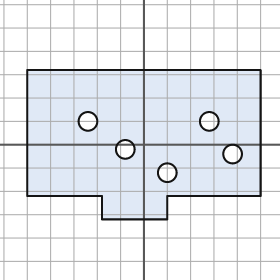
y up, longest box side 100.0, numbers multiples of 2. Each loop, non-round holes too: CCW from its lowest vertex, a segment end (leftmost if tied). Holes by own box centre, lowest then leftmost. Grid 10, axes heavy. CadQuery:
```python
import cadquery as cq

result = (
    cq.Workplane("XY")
    .moveTo(-18.0, -32.0)
    .lineTo(10.0, -32.0)
    .lineTo(10.0, -22.0)
    .lineTo(50.0, -22.0)
    .lineTo(50.0, 32.0)
    .lineTo(-50.0, 32.0)
    .lineTo(-50.0, -22.0)
    .lineTo(-18.0, -22.0)
    .close()
    .moveTo(10.0, -12.0)
    .circle(4.0)
    .moveTo(38.0, -4.0)
    .circle(4.0)
    .moveTo(-8.0, -2.0)
    .circle(4.0)
    .moveTo(-24.0, 10.0)
    .circle(4.0)
    .moveTo(28.0, 10.0)
    .circle(4.0)
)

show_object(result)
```